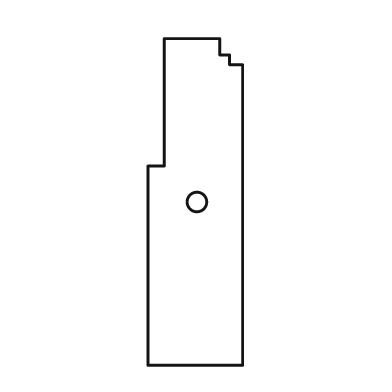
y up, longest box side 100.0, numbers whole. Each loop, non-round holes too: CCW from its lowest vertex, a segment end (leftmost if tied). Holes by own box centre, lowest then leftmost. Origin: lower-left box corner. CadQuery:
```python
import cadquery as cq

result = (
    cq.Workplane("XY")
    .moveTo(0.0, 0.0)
    .lineTo(29.0, 0.0)
    .lineTo(29.0, 92.0)
    .lineTo(25.0, 92.0)
    .lineTo(25.0, 95.0)
    .lineTo(22.0, 95.0)
    .lineTo(22.0, 100.0)
    .lineTo(5.0, 100.0)
    .lineTo(5.0, 61.0)
    .lineTo(0.0, 61.0)
    .close()
    .moveTo(15.0, 50.0)
    .circle(3.0)
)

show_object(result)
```